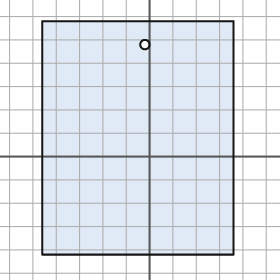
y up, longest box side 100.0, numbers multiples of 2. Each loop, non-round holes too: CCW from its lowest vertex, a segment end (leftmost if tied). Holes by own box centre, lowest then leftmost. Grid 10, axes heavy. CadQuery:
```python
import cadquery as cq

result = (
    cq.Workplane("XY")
    .moveTo(-46.0, -42.0)
    .lineTo(36.0, -42.0)
    .lineTo(36.0, 58.0)
    .lineTo(-46.0, 58.0)
    .close()
    .moveTo(-2.0, 48.0)
    .circle(2.0)
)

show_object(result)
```